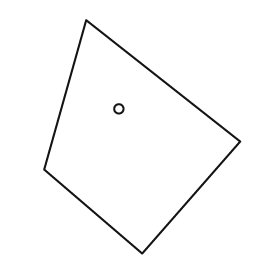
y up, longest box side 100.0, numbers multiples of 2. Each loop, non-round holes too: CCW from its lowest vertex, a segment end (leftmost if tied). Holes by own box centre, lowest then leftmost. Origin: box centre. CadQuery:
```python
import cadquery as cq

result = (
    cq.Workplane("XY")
    .moveTo(0.0, -50.0)
    .lineTo(42.0, -2.0)
    .lineTo(-24.0, 50.0)
    .lineTo(-42.0, -14.0)
    .close()
    .moveTo(-10.0, 12.0)
    .circle(2.0)
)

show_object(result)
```